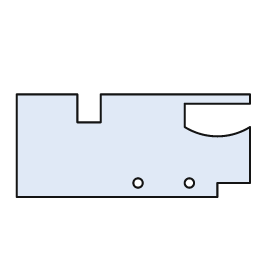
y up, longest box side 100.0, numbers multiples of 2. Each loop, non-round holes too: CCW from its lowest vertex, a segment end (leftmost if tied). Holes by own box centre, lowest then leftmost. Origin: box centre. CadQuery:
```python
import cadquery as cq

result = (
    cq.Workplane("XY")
    .moveTo(-50.0, -22.0)
    .lineTo(36.0, -22.0)
    .lineTo(36.0, -16.0)
    .lineTo(50.0, -16.0)
    .lineTo(50.0, 8.0)
    .threePointArc((36.0, 4.0), (22.0, 8.0))
    .lineTo(22.0, 18.0)
    .lineTo(50.0, 18.0)
    .lineTo(50.0, 22.0)
    .lineTo(-14.0, 22.0)
    .lineTo(-14.0, 10.0)
    .lineTo(-24.0, 10.0)
    .lineTo(-24.0, 22.0)
    .lineTo(-50.0, 22.0)
    .close()
    .moveTo(2.0, -16.0)
    .circle(2.0)
    .moveTo(24.0, -16.0)
    .circle(2.0)
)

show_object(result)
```